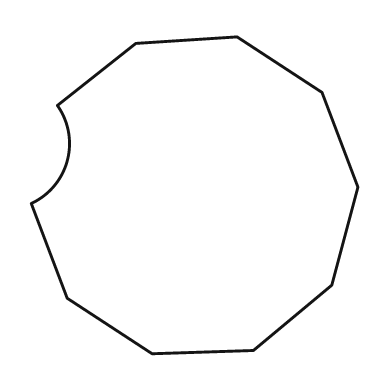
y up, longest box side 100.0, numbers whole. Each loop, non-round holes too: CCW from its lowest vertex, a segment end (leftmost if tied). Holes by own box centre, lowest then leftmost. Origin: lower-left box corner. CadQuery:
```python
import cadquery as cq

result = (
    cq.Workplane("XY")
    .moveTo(37.0, 0.0)
    .lineTo(68.0, 1.0)
    .lineTo(92.0, 21.0)
    .lineTo(100.0, 51.0)
    .lineTo(89.0, 80.0)
    .lineTo(63.0, 97.0)
    .lineTo(32.0, 95.0)
    .lineTo(8.0, 76.0)
    .threePointArc((11.0, 59.0), (0.0, 46.0))
    .lineTo(11.0, 17.0)
    .close()
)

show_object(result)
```